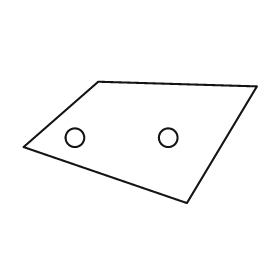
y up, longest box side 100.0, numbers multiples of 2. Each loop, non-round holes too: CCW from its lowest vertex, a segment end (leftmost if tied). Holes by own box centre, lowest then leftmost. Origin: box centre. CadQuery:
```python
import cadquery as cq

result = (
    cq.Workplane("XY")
    .moveTo(20.0, -26.0)
    .lineTo(50.0, 24.0)
    .lineTo(-18.0, 26.0)
    .lineTo(-50.0, -2.0)
    .close()
    .moveTo(-28.0, 2.0)
    .circle(4.0)
    .moveTo(12.0, 2.0)
    .circle(4.0)
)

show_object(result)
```